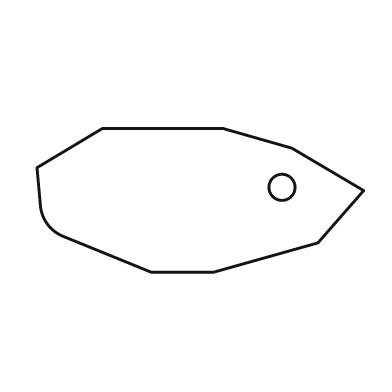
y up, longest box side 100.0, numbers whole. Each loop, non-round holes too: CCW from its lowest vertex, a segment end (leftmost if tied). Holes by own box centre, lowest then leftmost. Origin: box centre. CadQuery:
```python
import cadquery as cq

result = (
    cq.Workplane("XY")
    .moveTo(-15.0, -22.0)
    .lineTo(4.0, -22.0)
    .lineTo(36.0, -13.0)
    .lineTo(50.0, 3.0)
    .lineTo(28.0, 16.0)
    .lineTo(7.0, 22.0)
    .lineTo(-30.0, 22.0)
    .lineTo(-50.0, 10.0)
    .lineTo(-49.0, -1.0)
    .threePointArc((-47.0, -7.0), (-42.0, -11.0))
    .close()
    .moveTo(25.0, 4.0)
    .circle(4.0)
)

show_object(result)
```